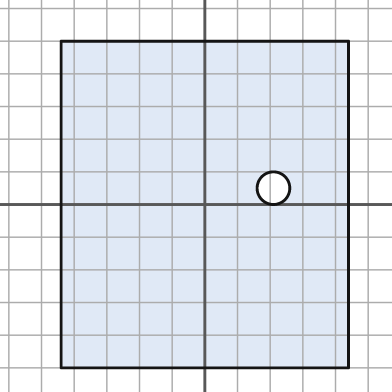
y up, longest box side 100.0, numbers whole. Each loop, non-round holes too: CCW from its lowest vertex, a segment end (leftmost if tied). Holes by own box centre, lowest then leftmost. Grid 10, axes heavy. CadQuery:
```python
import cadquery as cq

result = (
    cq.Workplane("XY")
    .moveTo(-44.0, -50.0)
    .lineTo(44.0, -50.0)
    .lineTo(44.0, 50.0)
    .lineTo(-44.0, 50.0)
    .close()
    .moveTo(21.0, 5.0)
    .circle(5.0)
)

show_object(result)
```